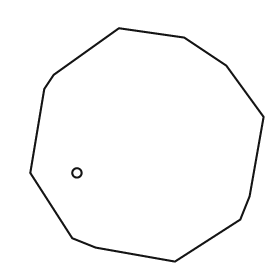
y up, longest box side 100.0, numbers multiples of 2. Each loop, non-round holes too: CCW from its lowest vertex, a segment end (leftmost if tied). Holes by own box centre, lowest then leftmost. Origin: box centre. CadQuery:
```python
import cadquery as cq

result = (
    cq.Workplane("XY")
    .moveTo(12.0, -50.0)
    .lineTo(40.0, -32.0)
    .lineTo(44.0, -22.0)
    .lineTo(50.0, 12.0)
    .lineTo(34.0, 34.0)
    .lineTo(16.0, 46.0)
    .lineTo(-12.0, 50.0)
    .lineTo(-40.0, 30.0)
    .lineTo(-44.0, 24.0)
    .lineTo(-50.0, -12.0)
    .lineTo(-32.0, -40.0)
    .lineTo(-22.0, -44.0)
    .close()
    .moveTo(-30.0, -12.0)
    .circle(2.0)
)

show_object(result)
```